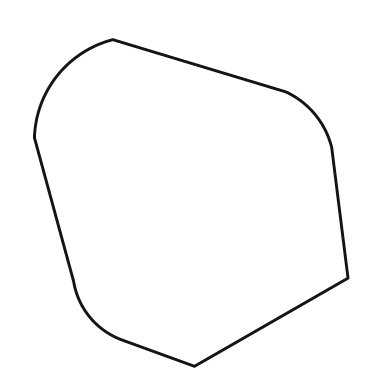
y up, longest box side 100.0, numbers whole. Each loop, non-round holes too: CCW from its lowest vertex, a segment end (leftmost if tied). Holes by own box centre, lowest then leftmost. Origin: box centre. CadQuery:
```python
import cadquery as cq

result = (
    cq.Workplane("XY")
    .moveTo(1.0, -50.0)
    .lineTo(48.0, -23.0)
    .lineTo(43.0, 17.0)
    .threePointArc((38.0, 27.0), (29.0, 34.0))
    .lineTo(-24.0, 50.0)
    .threePointArc((-41.0, 39.0), (-48.0, 20.0))
    .lineTo(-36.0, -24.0)
    .threePointArc((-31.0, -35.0), (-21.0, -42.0))
    .close()
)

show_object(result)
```